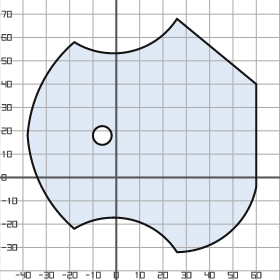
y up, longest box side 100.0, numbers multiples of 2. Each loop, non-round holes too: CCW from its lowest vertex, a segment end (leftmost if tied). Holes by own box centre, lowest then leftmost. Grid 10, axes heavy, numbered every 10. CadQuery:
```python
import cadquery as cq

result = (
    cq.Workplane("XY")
    .moveTo(26.0, -32.0)
    .threePointArc((48.0, -24.0), (60.0, -4.0))
    .lineTo(60.0, 40.0)
    .lineTo(26.0, 68.0)
    .threePointArc((6.0, 54.0), (-18.0, 58.0))
    .threePointArc((-32.0, 40.0), (-38.0, 18.0))
    .threePointArc((-32.0, -4.0), (-18.0, -22.0))
    .threePointArc((6.0, -18.0), (26.0, -32.0))
    .close()
    .moveTo(-6.0, 18.0)
    .circle(4.0)
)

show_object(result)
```